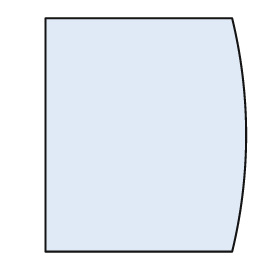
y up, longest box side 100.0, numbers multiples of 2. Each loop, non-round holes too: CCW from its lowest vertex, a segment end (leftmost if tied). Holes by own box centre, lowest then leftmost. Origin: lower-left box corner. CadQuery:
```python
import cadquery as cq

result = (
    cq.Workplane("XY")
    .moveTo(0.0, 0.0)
    .lineTo(80.0, 0.0)
    .threePointArc((86.0, 50.0), (80.0, 100.0))
    .lineTo(0.0, 100.0)
    .close()
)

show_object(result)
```